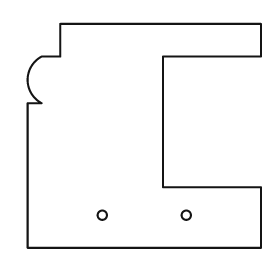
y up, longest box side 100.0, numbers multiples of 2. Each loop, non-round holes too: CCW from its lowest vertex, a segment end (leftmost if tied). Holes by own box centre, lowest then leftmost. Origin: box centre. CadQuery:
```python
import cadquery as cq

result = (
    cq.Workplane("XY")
    .moveTo(-50.0, -48.0)
    .lineTo(50.0, -48.0)
    .lineTo(50.0, -22.0)
    .lineTo(8.0, -22.0)
    .lineTo(8.0, 34.0)
    .lineTo(50.0, 34.0)
    .lineTo(50.0, 48.0)
    .lineTo(-36.0, 48.0)
    .lineTo(-36.0, 34.0)
    .lineTo(-44.0, 34.0)
    .threePointArc((-50.0, 24.0), (-44.0, 14.0))
    .lineTo(-50.0, 14.0)
    .close()
    .moveTo(-18.0, -34.0)
    .circle(2.0)
    .moveTo(18.0, -34.0)
    .circle(2.0)
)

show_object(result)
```